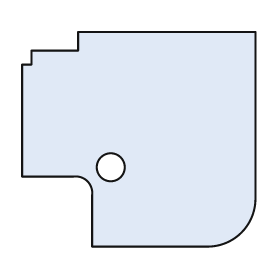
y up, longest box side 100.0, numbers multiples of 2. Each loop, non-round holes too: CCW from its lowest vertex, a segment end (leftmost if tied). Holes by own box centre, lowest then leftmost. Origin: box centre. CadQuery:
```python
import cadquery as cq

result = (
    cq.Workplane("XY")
    .moveTo(-20.0, -46.0)
    .lineTo(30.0, -46.0)
    .threePointArc((44.0, -40.0), (50.0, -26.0))
    .lineTo(50.0, 46.0)
    .lineTo(-26.0, 46.0)
    .lineTo(-26.0, 38.0)
    .lineTo(-46.0, 38.0)
    .lineTo(-46.0, 32.0)
    .lineTo(-50.0, 32.0)
    .lineTo(-50.0, -16.0)
    .lineTo(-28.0, -16.0)
    .threePointArc((-22.0, -18.0), (-20.0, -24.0))
    .close()
    .moveTo(-12.0, -12.0)
    .circle(6.0)
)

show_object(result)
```